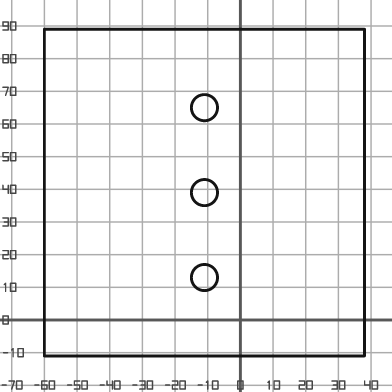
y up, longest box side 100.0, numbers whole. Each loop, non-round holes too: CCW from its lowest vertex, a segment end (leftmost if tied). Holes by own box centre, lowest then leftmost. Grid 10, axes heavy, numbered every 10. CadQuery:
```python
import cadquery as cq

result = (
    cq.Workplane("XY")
    .moveTo(-60.0, -11.0)
    .lineTo(38.0, -11.0)
    .lineTo(38.0, 89.0)
    .lineTo(-60.0, 89.0)
    .close()
    .moveTo(-11.0, 13.0)
    .circle(4.0)
    .moveTo(-11.0, 39.0)
    .circle(4.0)
    .moveTo(-11.0, 65.0)
    .circle(4.0)
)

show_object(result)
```